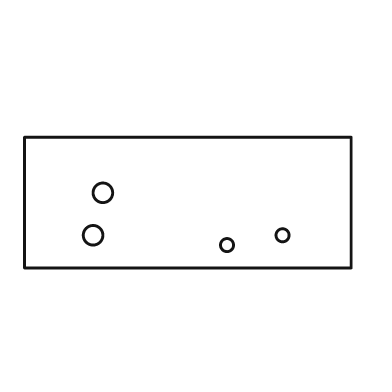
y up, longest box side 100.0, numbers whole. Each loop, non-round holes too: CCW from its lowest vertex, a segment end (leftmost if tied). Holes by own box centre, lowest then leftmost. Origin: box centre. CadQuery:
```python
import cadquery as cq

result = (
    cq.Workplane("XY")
    .moveTo(-50.0, -20.0)
    .lineTo(50.0, -20.0)
    .lineTo(50.0, 20.0)
    .lineTo(-50.0, 20.0)
    .close()
    .moveTo(12.0, -13.0)
    .circle(2.0)
    .moveTo(-29.0, -10.0)
    .circle(3.0)
    .moveTo(29.0, -10.0)
    .circle(2.0)
    .moveTo(-26.0, 3.0)
    .circle(3.0)
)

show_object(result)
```